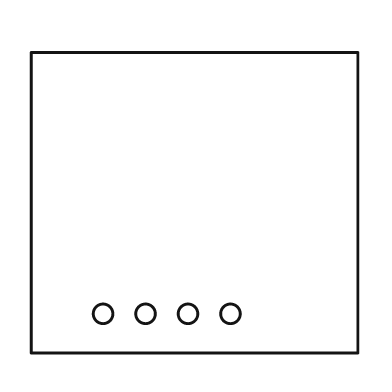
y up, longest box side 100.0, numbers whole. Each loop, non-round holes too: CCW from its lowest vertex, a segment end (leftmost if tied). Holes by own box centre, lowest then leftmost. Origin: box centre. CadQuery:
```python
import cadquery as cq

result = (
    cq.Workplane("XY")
    .moveTo(-50.0, -46.0)
    .lineTo(50.0, -46.0)
    .lineTo(50.0, 46.0)
    .lineTo(-50.0, 46.0)
    .close()
    .moveTo(-28.0, -34.0)
    .circle(3.0)
    .moveTo(-15.0, -34.0)
    .circle(3.0)
    .moveTo(-2.0, -34.0)
    .circle(3.0)
    .moveTo(11.0, -34.0)
    .circle(3.0)
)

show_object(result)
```